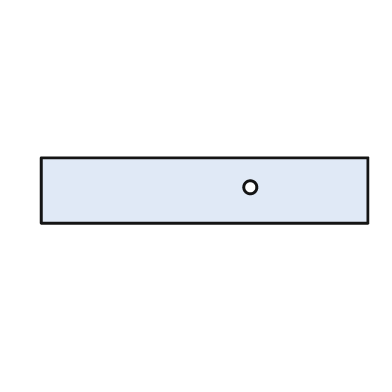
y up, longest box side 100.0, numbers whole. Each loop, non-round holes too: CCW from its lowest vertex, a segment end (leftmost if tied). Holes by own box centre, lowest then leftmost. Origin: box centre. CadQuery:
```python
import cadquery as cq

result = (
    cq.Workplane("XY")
    .moveTo(-50.0, -10.0)
    .lineTo(50.0, -10.0)
    .lineTo(50.0, 10.0)
    .lineTo(-50.0, 10.0)
    .close()
    .moveTo(14.0, 1.0)
    .circle(2.0)
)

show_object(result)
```